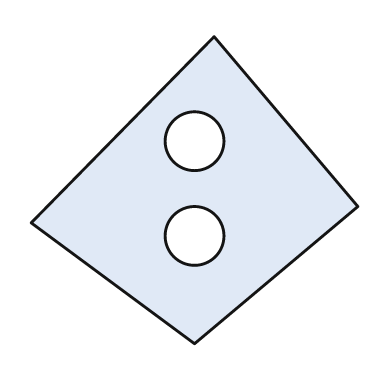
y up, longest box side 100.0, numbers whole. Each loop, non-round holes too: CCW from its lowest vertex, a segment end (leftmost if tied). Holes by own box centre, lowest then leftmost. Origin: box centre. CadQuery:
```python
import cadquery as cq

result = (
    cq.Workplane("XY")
    .moveTo(0.0, -47.0)
    .lineTo(50.0, -5.0)
    .lineTo(6.0, 47.0)
    .lineTo(-50.0, -10.0)
    .close()
    .moveTo(0.0, -14.0)
    .circle(9.0)
    .moveTo(0.0, 15.0)
    .circle(9.0)
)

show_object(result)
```